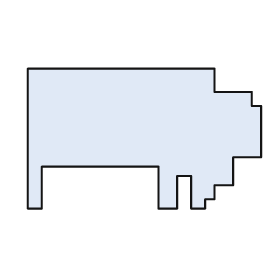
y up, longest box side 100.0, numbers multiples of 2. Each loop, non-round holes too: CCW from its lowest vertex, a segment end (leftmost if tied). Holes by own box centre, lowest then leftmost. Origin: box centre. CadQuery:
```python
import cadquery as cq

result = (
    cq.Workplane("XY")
    .moveTo(-50.0, -30.0)
    .lineTo(-44.0, -30.0)
    .lineTo(-44.0, -12.0)
    .lineTo(6.0, -12.0)
    .lineTo(6.0, -30.0)
    .lineTo(14.0, -30.0)
    .lineTo(14.0, -16.0)
    .lineTo(20.0, -16.0)
    .lineTo(20.0, -30.0)
    .lineTo(26.0, -30.0)
    .lineTo(26.0, -26.0)
    .lineTo(30.0, -26.0)
    .lineTo(30.0, -20.0)
    .lineTo(38.0, -20.0)
    .lineTo(38.0, -8.0)
    .lineTo(50.0, -8.0)
    .lineTo(50.0, 14.0)
    .lineTo(46.0, 14.0)
    .lineTo(46.0, 20.0)
    .lineTo(30.0, 20.0)
    .lineTo(30.0, 30.0)
    .lineTo(-50.0, 30.0)
    .close()
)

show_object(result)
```